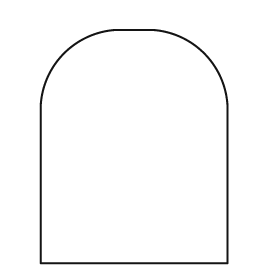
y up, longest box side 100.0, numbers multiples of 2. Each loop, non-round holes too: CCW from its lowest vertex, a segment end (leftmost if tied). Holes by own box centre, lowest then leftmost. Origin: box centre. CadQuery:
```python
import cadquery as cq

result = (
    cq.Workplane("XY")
    .moveTo(-40.0, -50.0)
    .lineTo(40.0, -50.0)
    .lineTo(40.0, 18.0)
    .threePointArc((30.0, 40.0), (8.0, 50.0))
    .lineTo(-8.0, 50.0)
    .threePointArc((-30.0, 40.0), (-40.0, 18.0))
    .close()
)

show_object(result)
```